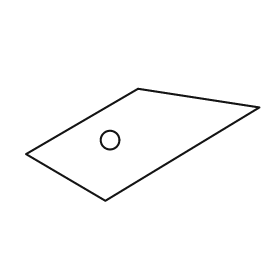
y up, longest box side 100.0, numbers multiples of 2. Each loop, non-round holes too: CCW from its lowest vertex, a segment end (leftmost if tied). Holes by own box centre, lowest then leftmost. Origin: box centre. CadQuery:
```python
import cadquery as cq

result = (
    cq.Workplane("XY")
    .moveTo(-16.0, -24.0)
    .lineTo(50.0, 16.0)
    .lineTo(-2.0, 24.0)
    .lineTo(-50.0, -4.0)
    .close()
    .moveTo(-14.0, 2.0)
    .circle(4.0)
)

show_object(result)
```